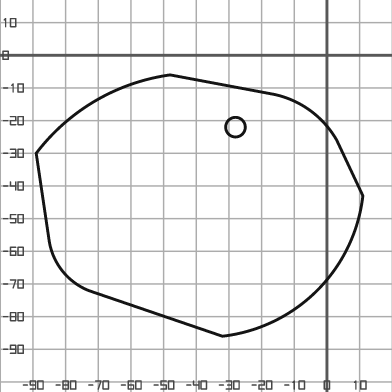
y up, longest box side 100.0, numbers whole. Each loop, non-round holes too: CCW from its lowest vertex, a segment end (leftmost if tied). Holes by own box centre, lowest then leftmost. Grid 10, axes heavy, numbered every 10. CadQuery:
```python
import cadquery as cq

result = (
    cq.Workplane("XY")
    .moveTo(-32.0, -86.0)
    .threePointArc((-3.0, -72.0), (11.0, -43.0))
    .lineTo(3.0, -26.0)
    .threePointArc((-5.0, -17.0), (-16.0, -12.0))
    .lineTo(-48.0, -6.0)
    .threePointArc((-71.0, -14.0), (-89.0, -30.0))
    .lineTo(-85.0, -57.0)
    .threePointArc((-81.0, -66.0), (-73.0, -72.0))
    .close()
    .moveTo(-28.0, -22.0)
    .circle(3.0)
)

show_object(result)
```